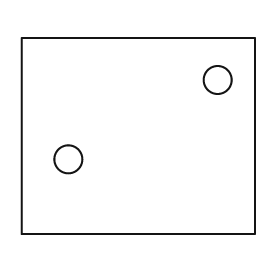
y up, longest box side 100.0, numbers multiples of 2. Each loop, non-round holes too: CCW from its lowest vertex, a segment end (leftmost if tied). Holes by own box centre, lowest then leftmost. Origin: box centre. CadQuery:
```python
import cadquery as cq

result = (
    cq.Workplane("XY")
    .moveTo(-50.0, -42.0)
    .lineTo(50.0, -42.0)
    .lineTo(50.0, 42.0)
    .lineTo(-50.0, 42.0)
    .close()
    .moveTo(-30.0, -10.0)
    .circle(6.0)
    .moveTo(34.0, 24.0)
    .circle(6.0)
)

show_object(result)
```